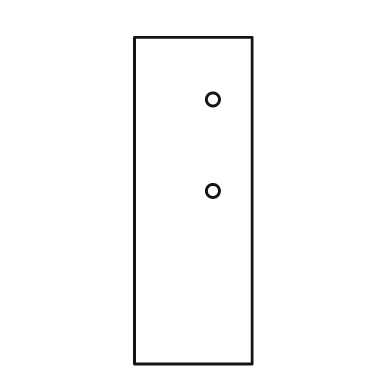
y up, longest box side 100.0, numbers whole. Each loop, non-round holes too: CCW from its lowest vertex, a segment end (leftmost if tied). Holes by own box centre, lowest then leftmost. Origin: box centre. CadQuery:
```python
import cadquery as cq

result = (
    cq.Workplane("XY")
    .moveTo(-18.0, -50.0)
    .lineTo(18.0, -50.0)
    .lineTo(18.0, 50.0)
    .lineTo(-18.0, 50.0)
    .close()
    .moveTo(6.0, 3.0)
    .circle(2.0)
    .moveTo(6.0, 31.0)
    .circle(2.0)
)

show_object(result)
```